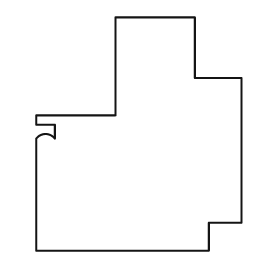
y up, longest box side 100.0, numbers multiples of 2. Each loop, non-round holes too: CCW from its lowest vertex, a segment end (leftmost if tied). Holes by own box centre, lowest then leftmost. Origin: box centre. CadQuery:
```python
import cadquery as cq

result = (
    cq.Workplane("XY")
    .moveTo(-44.0, -50.0)
    .lineTo(30.0, -50.0)
    .lineTo(30.0, -38.0)
    .lineTo(44.0, -38.0)
    .lineTo(44.0, 24.0)
    .lineTo(24.0, 24.0)
    .lineTo(24.0, 50.0)
    .lineTo(-10.0, 50.0)
    .lineTo(-10.0, 8.0)
    .lineTo(-44.0, 8.0)
    .lineTo(-44.0, 4.0)
    .lineTo(-36.0, 4.0)
    .lineTo(-36.0, -2.0)
    .threePointArc((-40.0, 0.0), (-44.0, -2.0))
    .close()
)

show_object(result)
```